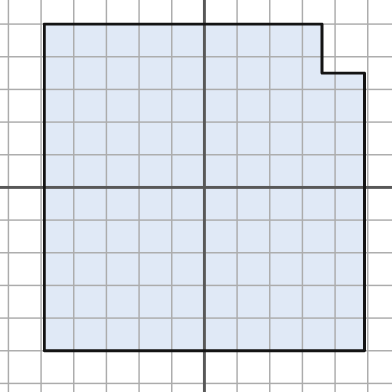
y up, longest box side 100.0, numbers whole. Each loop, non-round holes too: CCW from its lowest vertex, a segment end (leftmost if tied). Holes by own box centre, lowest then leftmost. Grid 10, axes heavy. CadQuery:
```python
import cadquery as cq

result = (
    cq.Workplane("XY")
    .moveTo(-49.0, -50.0)
    .lineTo(49.0, -50.0)
    .lineTo(49.0, 35.0)
    .lineTo(36.0, 35.0)
    .lineTo(36.0, 50.0)
    .lineTo(-49.0, 50.0)
    .close()
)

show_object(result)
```